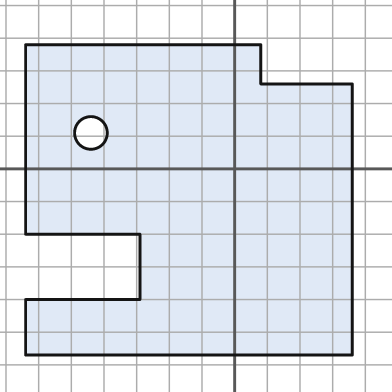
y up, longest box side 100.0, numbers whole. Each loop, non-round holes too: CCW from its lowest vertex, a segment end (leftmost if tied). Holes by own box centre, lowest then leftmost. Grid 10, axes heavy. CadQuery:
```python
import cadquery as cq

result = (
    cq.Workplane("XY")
    .moveTo(-64.0, -57.0)
    .lineTo(36.0, -57.0)
    .lineTo(36.0, 26.0)
    .lineTo(8.0, 26.0)
    .lineTo(8.0, 38.0)
    .lineTo(-64.0, 38.0)
    .lineTo(-64.0, -20.0)
    .lineTo(-29.0, -20.0)
    .lineTo(-29.0, -40.0)
    .lineTo(-64.0, -40.0)
    .close()
    .moveTo(-44.0, 11.0)
    .circle(5.0)
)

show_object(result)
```